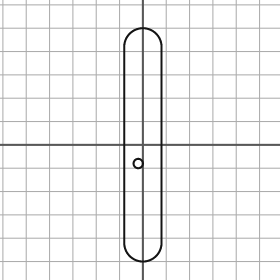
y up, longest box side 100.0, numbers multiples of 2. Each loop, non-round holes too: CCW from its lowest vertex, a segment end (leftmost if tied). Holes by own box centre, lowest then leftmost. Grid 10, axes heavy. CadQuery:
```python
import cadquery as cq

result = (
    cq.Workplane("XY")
    .moveTo(-8.0, -42.0)
    .threePointArc((0.0, -50.0), (8.0, -42.0))
    .lineTo(8.0, 42.0)
    .threePointArc((0.0, 50.0), (-8.0, 42.0))
    .close()
    .moveTo(-2.0, -8.0)
    .circle(2.0)
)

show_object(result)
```